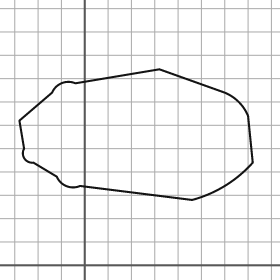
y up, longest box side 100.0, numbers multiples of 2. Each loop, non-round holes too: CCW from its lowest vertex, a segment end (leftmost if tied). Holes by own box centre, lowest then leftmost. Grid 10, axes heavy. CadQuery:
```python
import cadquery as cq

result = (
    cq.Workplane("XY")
    .moveTo(46.0, 28.0)
    .threePointArc((60.0, 34.0), (72.0, 44.0))
    .lineTo(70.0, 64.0)
    .threePointArc((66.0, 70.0), (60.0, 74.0))
    .lineTo(32.0, 84.0)
    .lineTo(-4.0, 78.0)
    .threePointArc((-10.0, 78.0), (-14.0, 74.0))
    .lineTo(-28.0, 62.0)
    .lineTo(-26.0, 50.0)
    .threePointArc((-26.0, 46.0), (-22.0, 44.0))
    .lineTo(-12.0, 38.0)
    .threePointArc((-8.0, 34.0), (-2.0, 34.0))
    .close()
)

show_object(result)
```